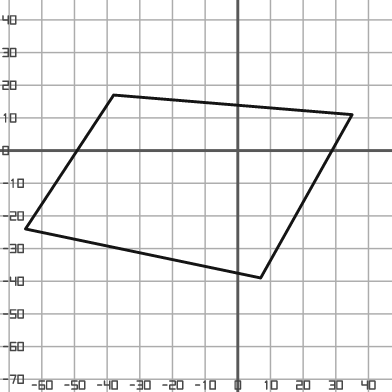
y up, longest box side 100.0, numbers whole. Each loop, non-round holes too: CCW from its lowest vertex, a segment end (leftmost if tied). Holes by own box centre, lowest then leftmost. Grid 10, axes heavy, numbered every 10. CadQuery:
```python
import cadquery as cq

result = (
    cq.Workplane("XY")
    .moveTo(7.0, -39.0)
    .lineTo(35.0, 11.0)
    .lineTo(-38.0, 17.0)
    .lineTo(-65.0, -24.0)
    .close()
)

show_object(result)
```